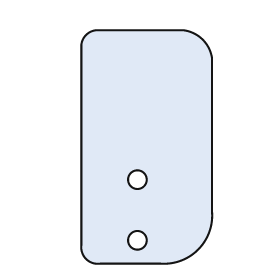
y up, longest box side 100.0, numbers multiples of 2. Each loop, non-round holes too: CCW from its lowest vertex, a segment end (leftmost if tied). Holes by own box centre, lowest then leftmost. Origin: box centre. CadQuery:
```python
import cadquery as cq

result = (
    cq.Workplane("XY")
    .moveTo(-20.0, -50.0)
    .lineTo(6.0, -50.0)
    .threePointArc((22.0, -44.0), (28.0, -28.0))
    .lineTo(28.0, 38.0)
    .threePointArc((24.0, 46.0), (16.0, 50.0))
    .lineTo(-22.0, 50.0)
    .threePointArc((-26.0, 48.0), (-28.0, 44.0))
    .lineTo(-28.0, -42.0)
    .threePointArc((-26.0, -48.0), (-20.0, -50.0))
    .close()
    .moveTo(-4.0, -40.0)
    .circle(4.0)
    .moveTo(-4.0, -14.0)
    .circle(4.0)
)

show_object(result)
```